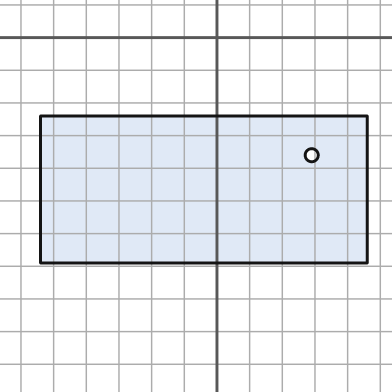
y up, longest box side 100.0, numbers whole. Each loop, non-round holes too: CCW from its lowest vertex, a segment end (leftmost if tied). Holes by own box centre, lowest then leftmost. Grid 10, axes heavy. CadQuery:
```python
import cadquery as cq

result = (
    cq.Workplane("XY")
    .moveTo(-54.0, -69.0)
    .lineTo(46.0, -69.0)
    .lineTo(46.0, -24.0)
    .lineTo(-54.0, -24.0)
    .close()
    .moveTo(29.0, -36.0)
    .circle(2.0)
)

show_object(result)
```